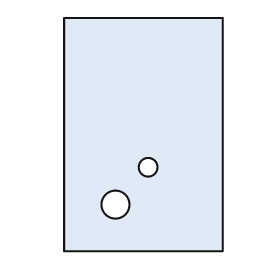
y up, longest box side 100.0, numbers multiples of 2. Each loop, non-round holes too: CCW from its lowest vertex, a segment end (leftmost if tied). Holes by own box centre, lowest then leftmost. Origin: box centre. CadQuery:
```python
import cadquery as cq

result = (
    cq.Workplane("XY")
    .moveTo(-34.0, -50.0)
    .lineTo(34.0, -50.0)
    .lineTo(34.0, 50.0)
    .lineTo(-34.0, 50.0)
    .close()
    .moveTo(-12.0, -30.0)
    .circle(6.0)
    .moveTo(2.0, -14.0)
    .circle(4.0)
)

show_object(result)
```